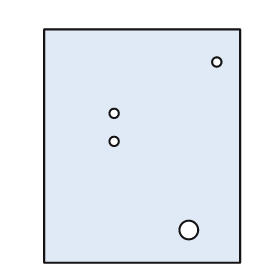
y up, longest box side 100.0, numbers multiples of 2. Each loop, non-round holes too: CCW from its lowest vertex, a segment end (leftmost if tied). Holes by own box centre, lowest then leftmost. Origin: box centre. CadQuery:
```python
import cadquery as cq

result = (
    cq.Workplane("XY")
    .moveTo(-42.0, -50.0)
    .lineTo(42.0, -50.0)
    .lineTo(42.0, 50.0)
    .lineTo(-42.0, 50.0)
    .close()
    .moveTo(20.0, -36.0)
    .circle(4.0)
    .moveTo(-12.0, 2.0)
    .circle(2.0)
    .moveTo(-12.0, 14.0)
    .circle(2.0)
    .moveTo(32.0, 36.0)
    .circle(2.0)
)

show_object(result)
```